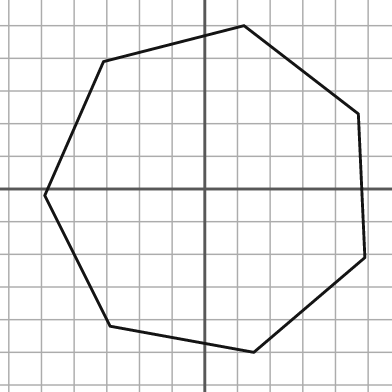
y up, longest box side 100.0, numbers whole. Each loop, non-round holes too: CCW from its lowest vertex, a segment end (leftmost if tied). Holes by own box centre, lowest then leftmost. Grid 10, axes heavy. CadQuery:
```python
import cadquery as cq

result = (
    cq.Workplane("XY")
    .moveTo(15.0, -50.0)
    .lineTo(49.0, -21.0)
    .lineTo(47.0, 23.0)
    .lineTo(12.0, 50.0)
    .lineTo(-31.0, 39.0)
    .lineTo(-49.0, -2.0)
    .lineTo(-29.0, -42.0)
    .close()
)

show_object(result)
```